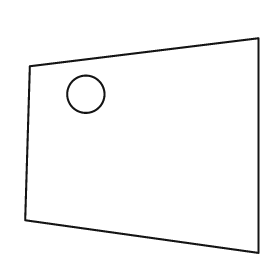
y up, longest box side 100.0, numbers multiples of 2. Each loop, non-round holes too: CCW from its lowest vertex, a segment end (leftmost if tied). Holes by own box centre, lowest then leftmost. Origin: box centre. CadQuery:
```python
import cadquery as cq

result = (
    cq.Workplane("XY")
    .moveTo(50.0, -46.0)
    .lineTo(50.0, 46.0)
    .lineTo(-48.0, 34.0)
    .lineTo(-50.0, -32.0)
    .close()
    .moveTo(-24.0, 22.0)
    .circle(8.0)
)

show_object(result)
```